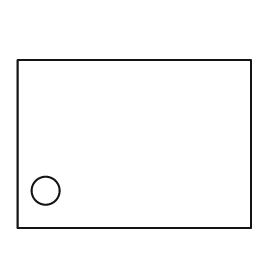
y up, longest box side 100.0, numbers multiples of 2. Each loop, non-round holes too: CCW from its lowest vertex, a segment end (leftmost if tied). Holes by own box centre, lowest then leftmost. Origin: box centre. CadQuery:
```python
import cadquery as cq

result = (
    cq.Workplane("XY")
    .moveTo(-50.0, -36.0)
    .lineTo(50.0, -36.0)
    .lineTo(50.0, 36.0)
    .lineTo(-50.0, 36.0)
    .close()
    .moveTo(-38.0, -20.0)
    .circle(6.0)
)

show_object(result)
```